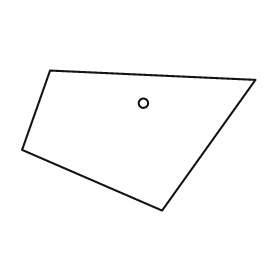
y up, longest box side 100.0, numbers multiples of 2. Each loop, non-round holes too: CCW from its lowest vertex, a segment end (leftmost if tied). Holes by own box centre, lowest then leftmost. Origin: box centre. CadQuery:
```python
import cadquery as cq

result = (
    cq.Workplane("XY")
    .moveTo(10.0, -30.0)
    .lineTo(50.0, 26.0)
    .lineTo(-38.0, 30.0)
    .lineTo(-50.0, -4.0)
    .close()
    .moveTo(2.0, 16.0)
    .circle(2.0)
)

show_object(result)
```